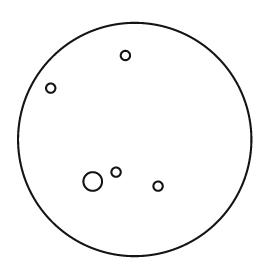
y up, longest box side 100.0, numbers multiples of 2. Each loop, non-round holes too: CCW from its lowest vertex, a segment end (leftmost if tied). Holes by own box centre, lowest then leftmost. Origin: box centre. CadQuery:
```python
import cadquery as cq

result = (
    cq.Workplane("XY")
    .moveTo(0.0, 0.0)
    .circle(50.0)
    .moveTo(10.0, -20.0)
    .circle(2.0)
    .moveTo(-18.0, -18.0)
    .circle(4.0)
    .moveTo(-8.0, -14.0)
    .circle(2.0)
    .moveTo(-36.0, 22.0)
    .circle(2.0)
    .moveTo(-4.0, 36.0)
    .circle(2.0)
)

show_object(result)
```